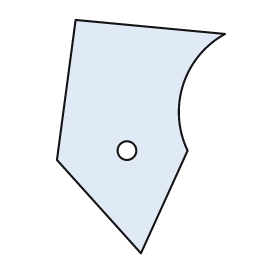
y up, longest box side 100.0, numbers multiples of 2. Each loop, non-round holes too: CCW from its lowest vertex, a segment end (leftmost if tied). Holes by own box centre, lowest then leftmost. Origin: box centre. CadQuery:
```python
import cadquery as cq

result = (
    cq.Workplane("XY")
    .moveTo(0.0, -50.0)
    .lineTo(20.0, -6.0)
    .threePointArc((18.0, 22.0), (36.0, 44.0))
    .lineTo(-28.0, 50.0)
    .lineTo(-36.0, -10.0)
    .close()
    .moveTo(-6.0, -6.0)
    .circle(4.0)
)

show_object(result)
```